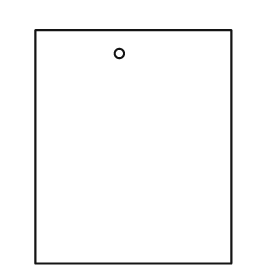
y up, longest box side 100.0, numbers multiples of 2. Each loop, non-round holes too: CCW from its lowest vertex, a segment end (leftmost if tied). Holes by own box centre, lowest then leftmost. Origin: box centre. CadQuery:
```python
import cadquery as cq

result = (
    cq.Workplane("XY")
    .moveTo(-42.0, -50.0)
    .lineTo(42.0, -50.0)
    .lineTo(42.0, 50.0)
    .lineTo(-42.0, 50.0)
    .close()
    .moveTo(-6.0, 40.0)
    .circle(2.0)
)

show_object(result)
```